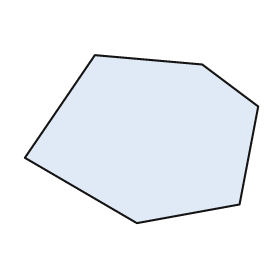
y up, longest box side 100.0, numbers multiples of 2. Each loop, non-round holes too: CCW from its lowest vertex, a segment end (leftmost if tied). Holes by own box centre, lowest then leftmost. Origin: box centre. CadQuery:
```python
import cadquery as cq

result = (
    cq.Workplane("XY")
    .moveTo(-2.0, -36.0)
    .lineTo(42.0, -28.0)
    .lineTo(50.0, 14.0)
    .lineTo(26.0, 32.0)
    .lineTo(-20.0, 36.0)
    .lineTo(-50.0, -8.0)
    .close()
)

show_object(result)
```